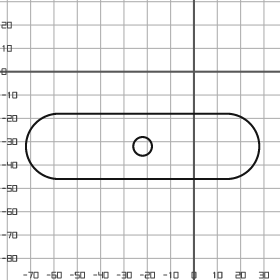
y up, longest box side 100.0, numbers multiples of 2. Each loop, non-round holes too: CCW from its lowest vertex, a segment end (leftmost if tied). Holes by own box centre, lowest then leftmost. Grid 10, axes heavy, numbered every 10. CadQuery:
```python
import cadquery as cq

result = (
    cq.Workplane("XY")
    .moveTo(-58.0, -46.0)
    .lineTo(14.0, -46.0)
    .threePointArc((28.0, -32.0), (14.0, -18.0))
    .lineTo(-58.0, -18.0)
    .threePointArc((-72.0, -32.0), (-58.0, -46.0))
    .close()
    .moveTo(-22.0, -32.0)
    .circle(4.0)
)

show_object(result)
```